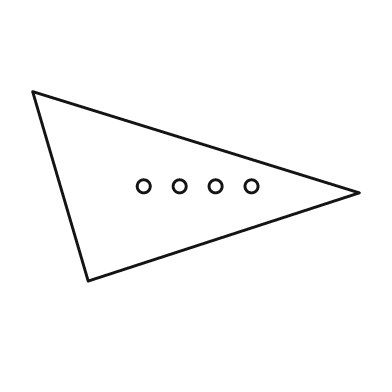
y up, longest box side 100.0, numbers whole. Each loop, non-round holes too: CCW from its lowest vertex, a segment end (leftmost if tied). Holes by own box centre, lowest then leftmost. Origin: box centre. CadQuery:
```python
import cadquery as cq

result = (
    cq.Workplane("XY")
    .moveTo(-33.0, -29.0)
    .lineTo(50.0, -2.0)
    .lineTo(-50.0, 29.0)
    .close()
    .moveTo(-16.0, 0.0)
    .circle(2.0)
    .moveTo(-5.0, 0.0)
    .circle(2.0)
    .moveTo(6.0, 0.0)
    .circle(2.0)
    .moveTo(17.0, 0.0)
    .circle(2.0)
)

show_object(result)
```